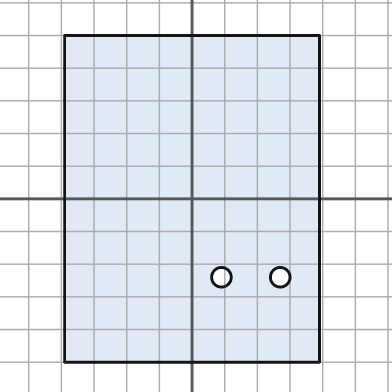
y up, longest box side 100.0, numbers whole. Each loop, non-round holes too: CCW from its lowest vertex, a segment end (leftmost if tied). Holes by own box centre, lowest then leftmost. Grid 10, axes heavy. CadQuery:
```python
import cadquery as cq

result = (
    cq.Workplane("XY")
    .moveTo(-39.0, -50.0)
    .lineTo(39.0, -50.0)
    .lineTo(39.0, 50.0)
    .lineTo(-39.0, 50.0)
    .close()
    .moveTo(9.0, -24.0)
    .circle(3.0)
    .moveTo(27.0, -24.0)
    .circle(3.0)
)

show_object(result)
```